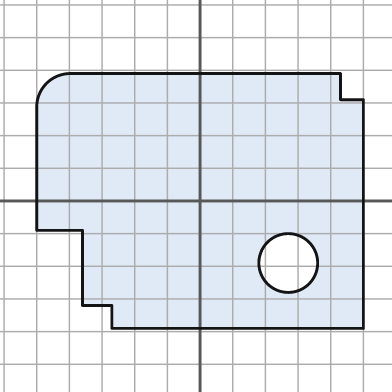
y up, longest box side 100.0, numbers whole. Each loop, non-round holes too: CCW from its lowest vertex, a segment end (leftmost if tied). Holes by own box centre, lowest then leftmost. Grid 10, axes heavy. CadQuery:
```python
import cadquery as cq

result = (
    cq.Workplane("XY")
    .moveTo(-27.0, -39.0)
    .lineTo(50.0, -39.0)
    .lineTo(50.0, 31.0)
    .lineTo(43.0, 31.0)
    .lineTo(43.0, 39.0)
    .lineTo(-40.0, 39.0)
    .threePointArc((-47.0, 36.0), (-50.0, 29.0))
    .lineTo(-50.0, -9.0)
    .lineTo(-36.0, -9.0)
    .lineTo(-36.0, -32.0)
    .lineTo(-27.0, -32.0)
    .close()
    .moveTo(27.0, -19.0)
    .circle(9.0)
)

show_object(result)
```